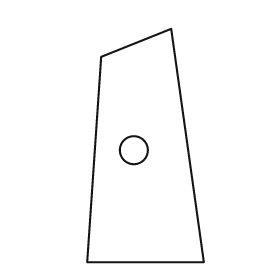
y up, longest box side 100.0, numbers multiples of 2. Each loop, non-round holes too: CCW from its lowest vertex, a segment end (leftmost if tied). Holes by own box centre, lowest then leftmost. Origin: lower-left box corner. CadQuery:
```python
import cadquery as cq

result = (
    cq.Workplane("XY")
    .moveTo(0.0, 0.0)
    .lineTo(50.0, 0.0)
    .lineTo(36.0, 100.0)
    .lineTo(6.0, 88.0)
    .close()
    .moveTo(20.0, 48.0)
    .circle(6.0)
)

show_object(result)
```